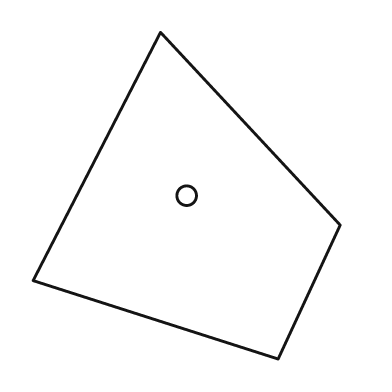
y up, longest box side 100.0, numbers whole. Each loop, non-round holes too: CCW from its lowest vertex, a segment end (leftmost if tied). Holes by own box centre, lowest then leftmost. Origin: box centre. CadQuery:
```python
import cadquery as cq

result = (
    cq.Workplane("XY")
    .moveTo(28.0, -50.0)
    .lineTo(47.0, -9.0)
    .lineTo(-8.0, 50.0)
    .lineTo(-47.0, -26.0)
    .close()
    .moveTo(0.0, 0.0)
    .circle(3.0)
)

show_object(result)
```